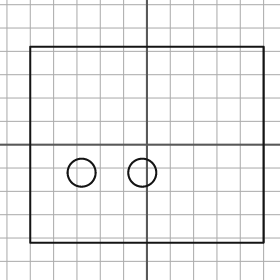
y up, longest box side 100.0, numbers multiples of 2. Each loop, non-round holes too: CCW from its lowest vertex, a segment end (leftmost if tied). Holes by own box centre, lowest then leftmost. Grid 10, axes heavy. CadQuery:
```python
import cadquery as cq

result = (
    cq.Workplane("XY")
    .moveTo(-50.0, -42.0)
    .lineTo(50.0, -42.0)
    .lineTo(50.0, 42.0)
    .lineTo(-50.0, 42.0)
    .close()
    .moveTo(-28.0, -12.0)
    .circle(6.0)
    .moveTo(-2.0, -12.0)
    .circle(6.0)
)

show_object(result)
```